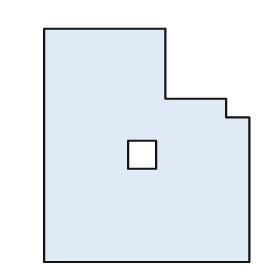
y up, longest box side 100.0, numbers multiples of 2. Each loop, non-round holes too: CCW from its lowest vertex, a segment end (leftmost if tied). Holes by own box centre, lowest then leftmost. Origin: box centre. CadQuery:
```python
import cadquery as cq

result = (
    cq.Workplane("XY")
    .moveTo(-44.0, -50.0)
    .lineTo(44.0, -50.0)
    .lineTo(44.0, 12.0)
    .lineTo(34.0, 12.0)
    .lineTo(34.0, 20.0)
    .lineTo(8.0, 20.0)
    .lineTo(8.0, 50.0)
    .lineTo(-44.0, 50.0)
    .close()
    .moveTo(-8.0, -10.0)
    .lineTo(4.0, -10.0)
    .lineTo(4.0, 2.0)
    .lineTo(-8.0, 2.0)
    .close()
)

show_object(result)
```